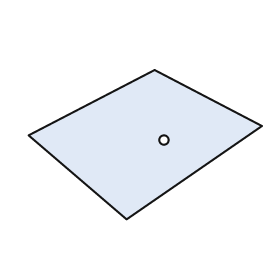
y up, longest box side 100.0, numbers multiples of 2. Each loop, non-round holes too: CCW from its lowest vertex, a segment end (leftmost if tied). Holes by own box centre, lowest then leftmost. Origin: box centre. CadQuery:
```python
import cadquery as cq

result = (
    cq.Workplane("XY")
    .moveTo(-8.0, -32.0)
    .lineTo(50.0, 8.0)
    .lineTo(4.0, 32.0)
    .lineTo(-50.0, 4.0)
    .close()
    .moveTo(8.0, 2.0)
    .circle(2.0)
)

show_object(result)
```